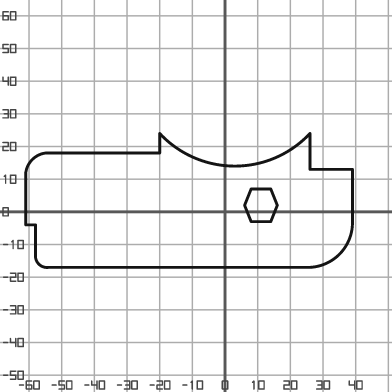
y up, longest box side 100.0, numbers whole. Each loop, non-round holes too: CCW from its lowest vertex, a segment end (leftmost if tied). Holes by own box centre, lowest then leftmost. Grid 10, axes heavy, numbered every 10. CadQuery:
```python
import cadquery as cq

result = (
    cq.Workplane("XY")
    .moveTo(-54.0, -17.0)
    .lineTo(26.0, -17.0)
    .threePointArc((35.0, -13.0), (39.0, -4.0))
    .lineTo(39.0, 13.0)
    .lineTo(26.0, 13.0)
    .lineTo(26.0, 24.0)
    .threePointArc((3.0, 14.0), (-20.0, 24.0))
    .lineTo(-20.0, 18.0)
    .lineTo(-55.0, 18.0)
    .threePointArc((-59.0, 16.0), (-61.0, 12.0))
    .lineTo(-61.0, -4.0)
    .lineTo(-58.0, -4.0)
    .lineTo(-58.0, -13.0)
    .threePointArc((-57.0, -16.0), (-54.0, -17.0))
    .close()
    .moveTo(8.0, -3.0)
    .lineTo(14.0, -3.0)
    .lineTo(16.0, 2.0)
    .lineTo(14.0, 7.0)
    .lineTo(8.0, 7.0)
    .lineTo(6.0, 2.0)
    .close()
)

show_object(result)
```